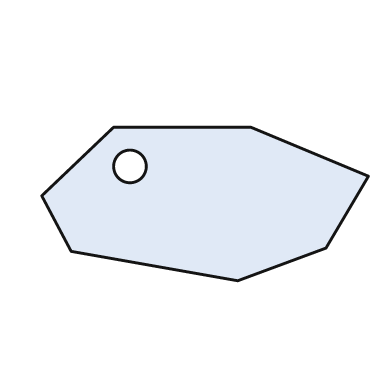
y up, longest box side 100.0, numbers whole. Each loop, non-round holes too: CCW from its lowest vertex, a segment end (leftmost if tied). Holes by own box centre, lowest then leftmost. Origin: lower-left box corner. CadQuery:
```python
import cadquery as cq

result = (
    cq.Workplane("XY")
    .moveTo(60.0, 0.0)
    .lineTo(87.0, 10.0)
    .lineTo(100.0, 32.0)
    .lineTo(64.0, 47.0)
    .lineTo(22.0, 47.0)
    .lineTo(0.0, 26.0)
    .lineTo(9.0, 9.0)
    .close()
    .moveTo(27.0, 35.0)
    .circle(5.0)
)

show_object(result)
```